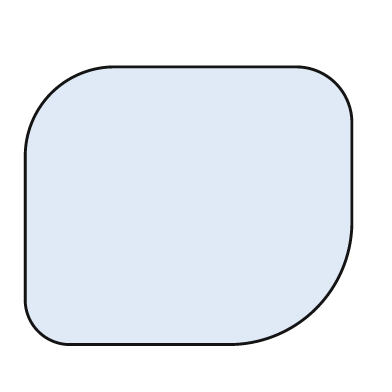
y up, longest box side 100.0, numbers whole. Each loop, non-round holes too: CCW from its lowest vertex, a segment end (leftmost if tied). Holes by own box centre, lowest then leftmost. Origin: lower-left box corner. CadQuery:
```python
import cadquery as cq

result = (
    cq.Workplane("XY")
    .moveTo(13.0, 0.0)
    .lineTo(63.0, 0.0)
    .threePointArc((89.0, 11.0), (100.0, 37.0))
    .lineTo(100.0, 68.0)
    .threePointArc((95.0, 80.0), (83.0, 85.0))
    .lineTo(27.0, 85.0)
    .threePointArc((8.0, 77.0), (0.0, 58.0))
    .lineTo(0.0, 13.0)
    .threePointArc((4.0, 4.0), (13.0, 0.0))
    .close()
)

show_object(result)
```